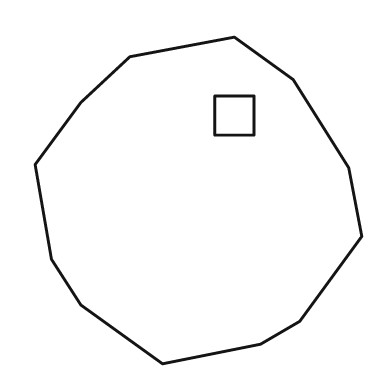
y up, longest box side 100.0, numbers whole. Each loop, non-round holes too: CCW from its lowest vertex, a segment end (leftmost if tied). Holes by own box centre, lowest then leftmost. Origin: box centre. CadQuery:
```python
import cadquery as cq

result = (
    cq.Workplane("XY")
    .moveTo(-11.0, -50.0)
    .lineTo(19.0, -44.0)
    .lineTo(31.0, -37.0)
    .lineTo(50.0, -11.0)
    .lineTo(46.0, 10.0)
    .lineTo(29.0, 37.0)
    .lineTo(11.0, 50.0)
    .lineTo(-21.0, 44.0)
    .lineTo(-36.0, 30.0)
    .lineTo(-50.0, 11.0)
    .lineTo(-45.0, -18.0)
    .lineTo(-36.0, -32.0)
    .close()
    .moveTo(5.0, 20.0)
    .lineTo(17.0, 20.0)
    .lineTo(17.0, 32.0)
    .lineTo(5.0, 32.0)
    .close()
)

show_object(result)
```